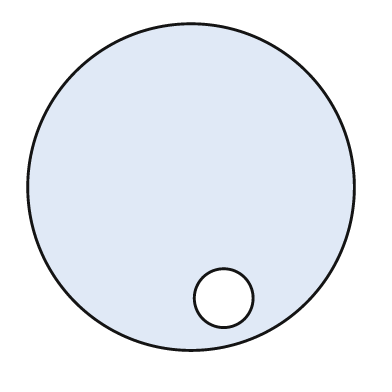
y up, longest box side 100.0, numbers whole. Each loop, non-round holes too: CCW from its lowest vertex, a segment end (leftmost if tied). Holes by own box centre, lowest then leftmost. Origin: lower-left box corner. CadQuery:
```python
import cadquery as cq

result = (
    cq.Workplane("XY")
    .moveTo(50.0, 50.0)
    .circle(50.0)
    .moveTo(60.0, 16.0)
    .circle(9.0)
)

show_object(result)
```